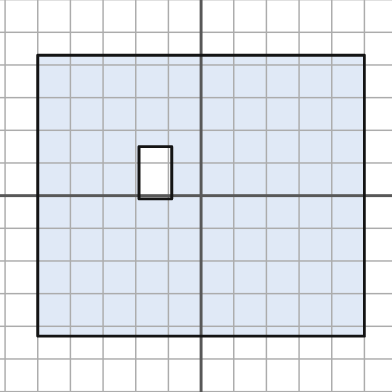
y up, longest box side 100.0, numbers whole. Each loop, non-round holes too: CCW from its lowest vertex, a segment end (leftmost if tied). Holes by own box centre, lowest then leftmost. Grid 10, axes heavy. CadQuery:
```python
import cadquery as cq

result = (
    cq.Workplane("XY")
    .moveTo(-50.0, -43.0)
    .lineTo(50.0, -43.0)
    .lineTo(50.0, 43.0)
    .lineTo(-50.0, 43.0)
    .close()
    .moveTo(-19.0, -1.0)
    .lineTo(-9.0, -1.0)
    .lineTo(-9.0, 15.0)
    .lineTo(-19.0, 15.0)
    .close()
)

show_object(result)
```